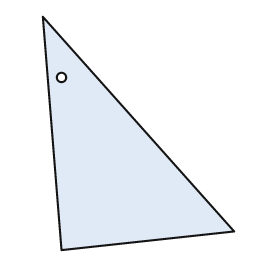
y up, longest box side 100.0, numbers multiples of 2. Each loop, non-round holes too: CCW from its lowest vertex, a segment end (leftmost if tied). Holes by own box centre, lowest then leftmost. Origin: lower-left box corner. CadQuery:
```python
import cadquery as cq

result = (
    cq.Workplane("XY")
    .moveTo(8.0, 0.0)
    .lineTo(82.0, 8.0)
    .lineTo(0.0, 100.0)
    .close()
    .moveTo(8.0, 74.0)
    .circle(2.0)
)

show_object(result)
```